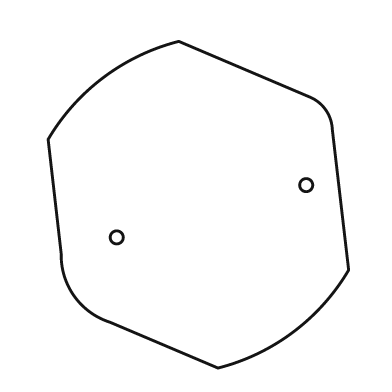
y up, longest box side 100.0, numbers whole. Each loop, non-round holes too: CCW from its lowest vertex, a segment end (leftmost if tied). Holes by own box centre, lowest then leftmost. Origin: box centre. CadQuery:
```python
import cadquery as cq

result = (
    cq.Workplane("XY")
    .moveTo(6.0, -50.0)
    .threePointArc((29.0, -39.0), (46.0, -20.0))
    .lineTo(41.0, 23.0)
    .threePointArc((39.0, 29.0), (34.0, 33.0))
    .lineTo(-6.0, 50.0)
    .threePointArc((-29.0, 39.0), (-46.0, 20.0))
    .lineTo(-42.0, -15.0)
    .threePointArc((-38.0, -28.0), (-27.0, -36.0))
    .close()
    .moveTo(-25.0, -10.0)
    .circle(2.0)
    .moveTo(33.0, 6.0)
    .circle(2.0)
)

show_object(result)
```